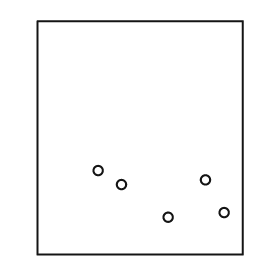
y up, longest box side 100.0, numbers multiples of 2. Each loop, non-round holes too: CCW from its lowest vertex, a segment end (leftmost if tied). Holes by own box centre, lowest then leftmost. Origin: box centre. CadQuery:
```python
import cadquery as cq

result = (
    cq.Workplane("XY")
    .moveTo(-44.0, -50.0)
    .lineTo(44.0, -50.0)
    .lineTo(44.0, 50.0)
    .lineTo(-44.0, 50.0)
    .close()
    .moveTo(12.0, -34.0)
    .circle(2.0)
    .moveTo(36.0, -32.0)
    .circle(2.0)
    .moveTo(-8.0, -20.0)
    .circle(2.0)
    .moveTo(28.0, -18.0)
    .circle(2.0)
    .moveTo(-18.0, -14.0)
    .circle(2.0)
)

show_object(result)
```